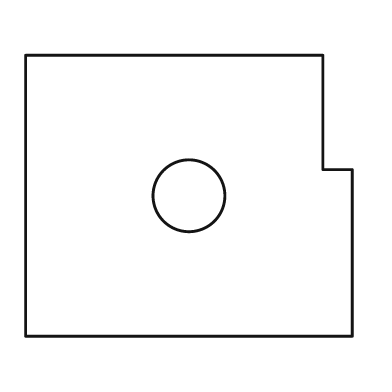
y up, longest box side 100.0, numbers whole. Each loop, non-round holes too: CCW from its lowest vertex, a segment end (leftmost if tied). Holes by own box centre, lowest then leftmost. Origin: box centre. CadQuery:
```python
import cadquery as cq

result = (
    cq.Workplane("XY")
    .moveTo(-50.0, -43.0)
    .lineTo(50.0, -43.0)
    .lineTo(50.0, 8.0)
    .lineTo(41.0, 8.0)
    .lineTo(41.0, 43.0)
    .lineTo(-50.0, 43.0)
    .close()
    .moveTo(0.0, 0.0)
    .circle(11.0)
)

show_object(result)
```